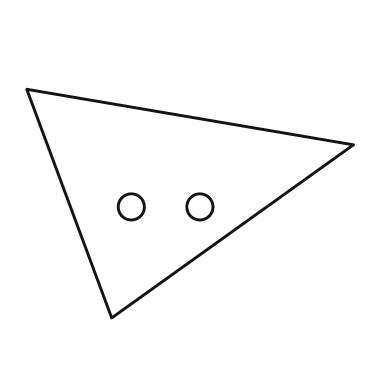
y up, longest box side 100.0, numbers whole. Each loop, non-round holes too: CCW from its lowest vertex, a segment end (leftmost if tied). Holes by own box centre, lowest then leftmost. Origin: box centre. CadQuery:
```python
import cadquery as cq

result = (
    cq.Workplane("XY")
    .moveTo(-24.0, -35.0)
    .lineTo(50.0, 18.0)
    .lineTo(-50.0, 35.0)
    .close()
    .moveTo(-18.0, -1.0)
    .circle(4.0)
    .moveTo(3.0, -1.0)
    .circle(4.0)
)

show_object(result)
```